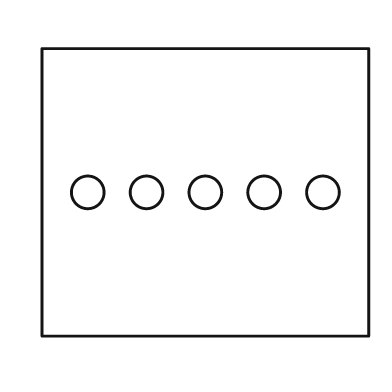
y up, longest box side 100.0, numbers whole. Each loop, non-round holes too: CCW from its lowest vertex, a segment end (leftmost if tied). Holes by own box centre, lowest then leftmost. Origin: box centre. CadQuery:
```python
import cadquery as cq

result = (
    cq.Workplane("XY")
    .moveTo(-50.0, -44.0)
    .lineTo(50.0, -44.0)
    .lineTo(50.0, 44.0)
    .lineTo(-50.0, 44.0)
    .close()
    .moveTo(-36.0, 0.0)
    .circle(5.0)
    .moveTo(-18.0, 0.0)
    .circle(5.0)
    .moveTo(0.0, 0.0)
    .circle(5.0)
    .moveTo(18.0, 0.0)
    .circle(5.0)
    .moveTo(36.0, 0.0)
    .circle(5.0)
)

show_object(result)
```